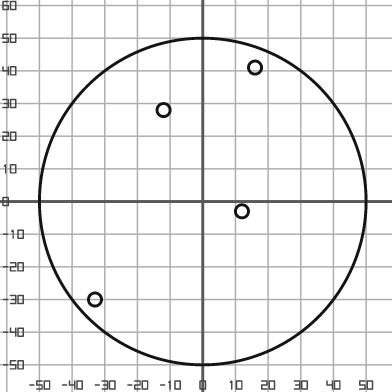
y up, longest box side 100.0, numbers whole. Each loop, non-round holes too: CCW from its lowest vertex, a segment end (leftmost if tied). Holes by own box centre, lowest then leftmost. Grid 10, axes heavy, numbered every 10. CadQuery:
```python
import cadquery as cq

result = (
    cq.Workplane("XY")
    .moveTo(0.0, 0.0)
    .circle(50.0)
    .moveTo(-33.0, -30.0)
    .circle(2.0)
    .moveTo(12.0, -3.0)
    .circle(2.0)
    .moveTo(-12.0, 28.0)
    .circle(2.0)
    .moveTo(16.0, 41.0)
    .circle(2.0)
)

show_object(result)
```